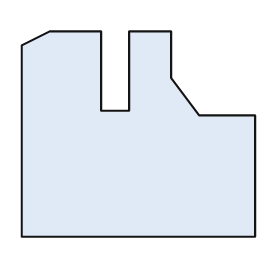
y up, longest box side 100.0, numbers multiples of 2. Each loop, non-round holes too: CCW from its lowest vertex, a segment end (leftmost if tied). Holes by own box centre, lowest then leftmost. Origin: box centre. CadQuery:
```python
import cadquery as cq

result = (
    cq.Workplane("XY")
    .moveTo(-50.0, -44.0)
    .lineTo(50.0, -44.0)
    .lineTo(50.0, 8.0)
    .lineTo(26.0, 8.0)
    .lineTo(14.0, 24.0)
    .lineTo(14.0, 44.0)
    .lineTo(-4.0, 44.0)
    .lineTo(-4.0, 10.0)
    .lineTo(-16.0, 10.0)
    .lineTo(-16.0, 44.0)
    .lineTo(-38.0, 44.0)
    .lineTo(-50.0, 38.0)
    .close()
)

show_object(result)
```